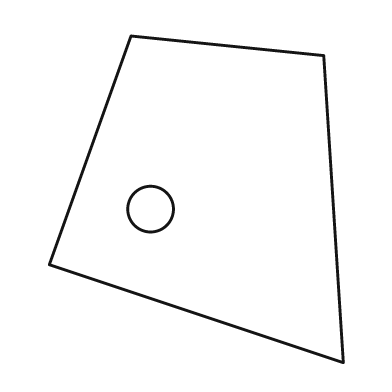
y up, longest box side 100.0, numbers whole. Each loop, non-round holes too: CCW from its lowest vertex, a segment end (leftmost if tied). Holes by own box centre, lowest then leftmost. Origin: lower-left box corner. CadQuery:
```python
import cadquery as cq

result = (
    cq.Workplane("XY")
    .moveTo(90.0, 0.0)
    .lineTo(84.0, 94.0)
    .lineTo(25.0, 100.0)
    .lineTo(0.0, 30.0)
    .close()
    .moveTo(31.0, 47.0)
    .circle(7.0)
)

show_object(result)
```